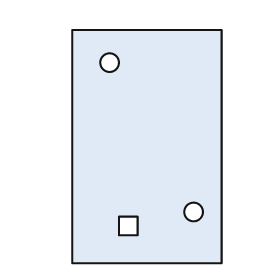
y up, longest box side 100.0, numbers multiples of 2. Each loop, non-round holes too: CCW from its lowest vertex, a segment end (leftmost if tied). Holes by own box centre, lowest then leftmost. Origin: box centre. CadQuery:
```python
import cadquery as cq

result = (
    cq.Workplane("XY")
    .moveTo(-32.0, -50.0)
    .lineTo(32.0, -50.0)
    .lineTo(32.0, 50.0)
    .lineTo(-32.0, 50.0)
    .close()
    .moveTo(-12.0, -38.0)
    .lineTo(-4.0, -38.0)
    .lineTo(-4.0, -30.0)
    .lineTo(-12.0, -30.0)
    .close()
    .moveTo(20.0, -28.0)
    .circle(4.0)
    .moveTo(-16.0, 36.0)
    .circle(4.0)
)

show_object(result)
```